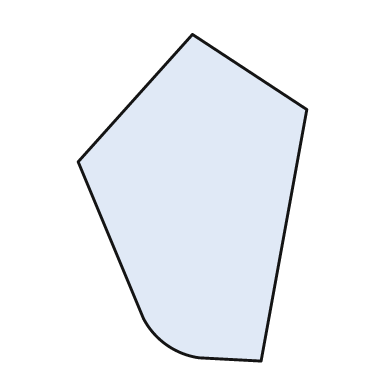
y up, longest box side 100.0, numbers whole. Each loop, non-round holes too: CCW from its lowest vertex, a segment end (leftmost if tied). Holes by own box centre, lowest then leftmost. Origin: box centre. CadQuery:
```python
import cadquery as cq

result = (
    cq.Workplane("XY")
    .moveTo(21.0, -50.0)
    .lineTo(35.0, 27.0)
    .lineTo(0.0, 50.0)
    .lineTo(-35.0, 11.0)
    .lineTo(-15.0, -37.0)
    .threePointArc((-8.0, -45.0), (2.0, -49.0))
    .close()
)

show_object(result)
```